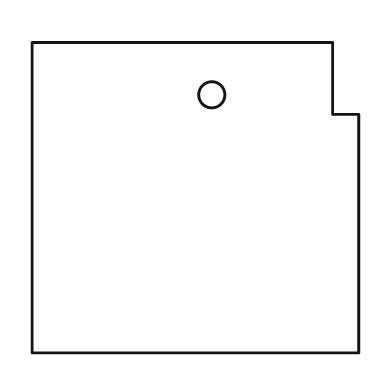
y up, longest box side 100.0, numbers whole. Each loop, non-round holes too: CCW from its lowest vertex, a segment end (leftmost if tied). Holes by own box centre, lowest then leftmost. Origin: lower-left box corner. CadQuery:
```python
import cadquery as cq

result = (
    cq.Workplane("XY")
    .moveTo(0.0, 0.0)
    .lineTo(100.0, 0.0)
    .lineTo(100.0, 73.0)
    .lineTo(92.0, 73.0)
    .lineTo(92.0, 95.0)
    .lineTo(0.0, 95.0)
    .close()
    .moveTo(55.0, 79.0)
    .circle(4.0)
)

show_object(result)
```